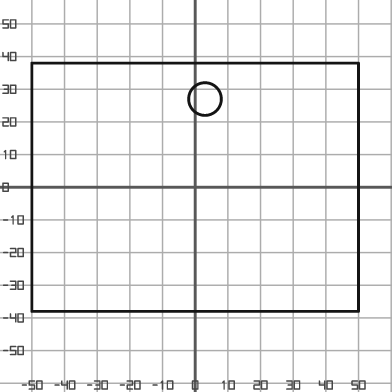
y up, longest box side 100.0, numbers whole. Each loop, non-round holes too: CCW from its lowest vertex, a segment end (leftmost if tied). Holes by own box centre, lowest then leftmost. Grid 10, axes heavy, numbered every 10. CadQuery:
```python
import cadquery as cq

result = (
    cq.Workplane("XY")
    .moveTo(-50.0, -38.0)
    .lineTo(50.0, -38.0)
    .lineTo(50.0, 38.0)
    .lineTo(-50.0, 38.0)
    .close()
    .moveTo(3.0, 27.0)
    .circle(5.0)
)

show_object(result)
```